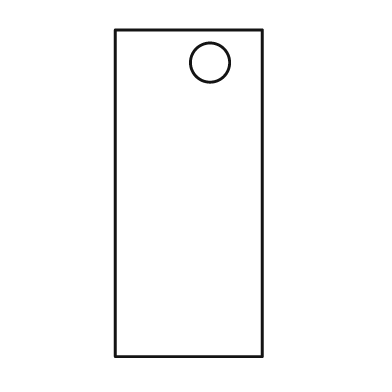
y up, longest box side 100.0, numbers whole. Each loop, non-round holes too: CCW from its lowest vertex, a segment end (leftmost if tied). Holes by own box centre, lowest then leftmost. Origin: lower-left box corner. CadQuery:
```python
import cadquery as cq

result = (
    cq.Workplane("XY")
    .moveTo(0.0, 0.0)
    .lineTo(45.0, 0.0)
    .lineTo(45.0, 100.0)
    .lineTo(0.0, 100.0)
    .close()
    .moveTo(29.0, 90.0)
    .circle(6.0)
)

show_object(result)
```